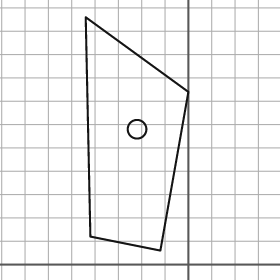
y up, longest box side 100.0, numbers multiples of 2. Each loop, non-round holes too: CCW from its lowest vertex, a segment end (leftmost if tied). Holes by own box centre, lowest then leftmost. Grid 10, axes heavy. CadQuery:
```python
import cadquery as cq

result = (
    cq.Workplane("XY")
    .moveTo(-12.0, 6.0)
    .lineTo(0.0, 74.0)
    .lineTo(-44.0, 106.0)
    .lineTo(-42.0, 12.0)
    .close()
    .moveTo(-22.0, 58.0)
    .circle(4.0)
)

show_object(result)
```